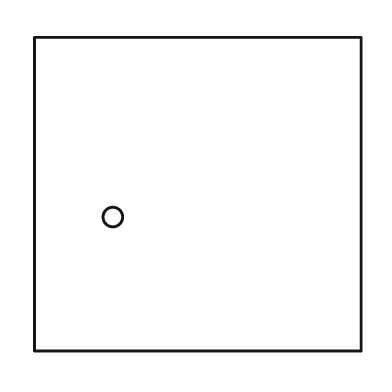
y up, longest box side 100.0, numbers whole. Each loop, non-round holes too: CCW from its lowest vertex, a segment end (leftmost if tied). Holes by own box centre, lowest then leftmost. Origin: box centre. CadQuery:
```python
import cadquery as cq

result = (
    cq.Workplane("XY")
    .moveTo(-50.0, -48.0)
    .lineTo(50.0, -48.0)
    .lineTo(50.0, 48.0)
    .lineTo(-50.0, 48.0)
    .close()
    .moveTo(-26.0, -7.0)
    .circle(3.0)
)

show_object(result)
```